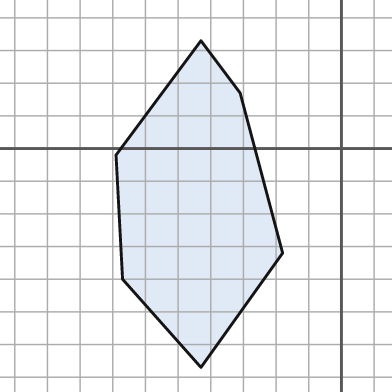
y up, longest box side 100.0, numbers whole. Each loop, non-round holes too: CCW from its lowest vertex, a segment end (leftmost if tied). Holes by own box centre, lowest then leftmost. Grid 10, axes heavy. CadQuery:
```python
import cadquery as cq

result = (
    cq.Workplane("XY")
    .moveTo(-43.0, -67.0)
    .lineTo(-18.0, -32.0)
    .lineTo(-31.0, 17.0)
    .lineTo(-43.0, 33.0)
    .lineTo(-69.0, -2.0)
    .lineTo(-67.0, -40.0)
    .close()
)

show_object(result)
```